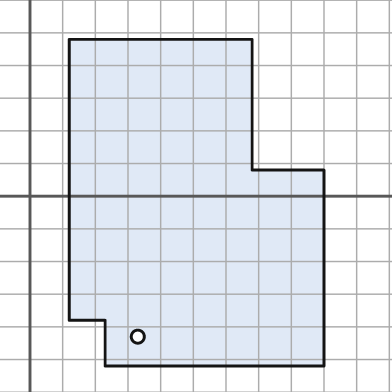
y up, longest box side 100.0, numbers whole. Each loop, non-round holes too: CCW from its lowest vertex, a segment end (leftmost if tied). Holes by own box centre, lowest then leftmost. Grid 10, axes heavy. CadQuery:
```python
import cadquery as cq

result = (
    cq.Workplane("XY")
    .moveTo(23.0, -52.0)
    .lineTo(90.0, -52.0)
    .lineTo(90.0, 8.0)
    .lineTo(68.0, 8.0)
    .lineTo(68.0, 48.0)
    .lineTo(12.0, 48.0)
    .lineTo(12.0, -38.0)
    .lineTo(23.0, -38.0)
    .close()
    .moveTo(33.0, -43.0)
    .circle(2.0)
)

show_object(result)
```